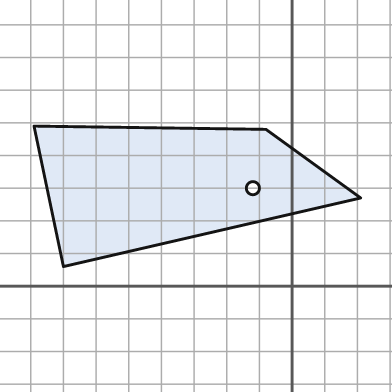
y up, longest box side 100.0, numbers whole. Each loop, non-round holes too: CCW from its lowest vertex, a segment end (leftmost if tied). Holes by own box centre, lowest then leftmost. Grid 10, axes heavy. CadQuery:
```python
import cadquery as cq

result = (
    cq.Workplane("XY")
    .moveTo(-70.0, 6.0)
    .lineTo(21.0, 27.0)
    .lineTo(-8.0, 48.0)
    .lineTo(-79.0, 49.0)
    .close()
    .moveTo(-12.0, 30.0)
    .circle(2.0)
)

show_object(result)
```